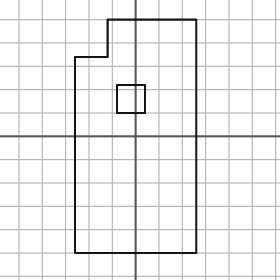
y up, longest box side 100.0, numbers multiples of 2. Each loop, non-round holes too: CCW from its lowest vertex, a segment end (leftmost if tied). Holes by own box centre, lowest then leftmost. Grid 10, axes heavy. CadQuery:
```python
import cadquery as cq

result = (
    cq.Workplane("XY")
    .moveTo(-26.0, -50.0)
    .lineTo(26.0, -50.0)
    .lineTo(26.0, 50.0)
    .lineTo(-12.0, 50.0)
    .lineTo(-12.0, 34.0)
    .lineTo(-26.0, 34.0)
    .close()
    .moveTo(-8.0, 10.0)
    .lineTo(4.0, 10.0)
    .lineTo(4.0, 22.0)
    .lineTo(-8.0, 22.0)
    .close()
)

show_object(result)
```